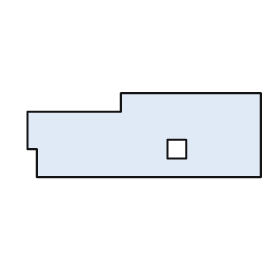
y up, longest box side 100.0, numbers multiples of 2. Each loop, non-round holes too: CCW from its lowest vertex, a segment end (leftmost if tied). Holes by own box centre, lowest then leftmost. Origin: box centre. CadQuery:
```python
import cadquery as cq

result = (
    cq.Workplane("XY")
    .moveTo(-46.0, -18.0)
    .lineTo(50.0, -18.0)
    .lineTo(50.0, 18.0)
    .lineTo(-10.0, 18.0)
    .lineTo(-10.0, 10.0)
    .lineTo(-50.0, 10.0)
    .lineTo(-50.0, -6.0)
    .lineTo(-46.0, -6.0)
    .close()
    .moveTo(10.0, -10.0)
    .lineTo(18.0, -10.0)
    .lineTo(18.0, -2.0)
    .lineTo(10.0, -2.0)
    .close()
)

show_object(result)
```